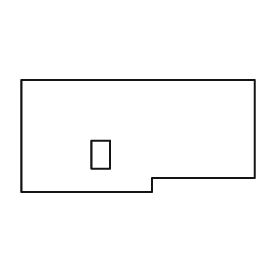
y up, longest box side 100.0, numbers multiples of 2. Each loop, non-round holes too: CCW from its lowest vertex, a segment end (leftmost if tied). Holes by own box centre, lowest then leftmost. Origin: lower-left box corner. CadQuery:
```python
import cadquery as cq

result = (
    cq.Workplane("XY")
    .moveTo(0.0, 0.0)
    .lineTo(56.0, 0.0)
    .lineTo(56.0, 6.0)
    .lineTo(100.0, 6.0)
    .lineTo(100.0, 48.0)
    .lineTo(0.0, 48.0)
    .close()
    .moveTo(30.0, 10.0)
    .lineTo(38.0, 10.0)
    .lineTo(38.0, 22.0)
    .lineTo(30.0, 22.0)
    .close()
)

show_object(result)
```